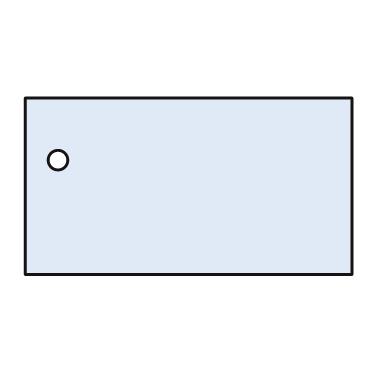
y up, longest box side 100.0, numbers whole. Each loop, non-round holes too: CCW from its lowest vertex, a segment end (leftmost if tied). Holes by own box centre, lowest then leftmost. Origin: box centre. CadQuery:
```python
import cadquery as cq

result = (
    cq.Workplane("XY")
    .moveTo(-50.0, -27.0)
    .lineTo(50.0, -27.0)
    .lineTo(50.0, 27.0)
    .lineTo(-50.0, 27.0)
    .close()
    .moveTo(-40.0, 8.0)
    .circle(3.0)
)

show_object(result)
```